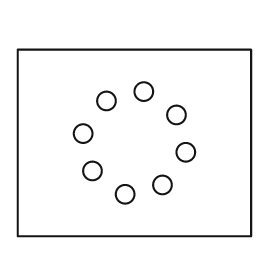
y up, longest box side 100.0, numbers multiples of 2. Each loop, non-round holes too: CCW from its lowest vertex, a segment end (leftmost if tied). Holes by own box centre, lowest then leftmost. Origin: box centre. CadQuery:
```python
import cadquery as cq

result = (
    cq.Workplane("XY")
    .moveTo(-50.0, -40.0)
    .lineTo(50.0, -40.0)
    .lineTo(50.0, 40.0)
    .lineTo(-50.0, 40.0)
    .close()
    .moveTo(-4.0, -22.0)
    .circle(4.0)
    .moveTo(12.0, -18.0)
    .circle(4.0)
    .moveTo(-18.0, -12.0)
    .circle(4.0)
    .moveTo(22.0, -4.0)
    .circle(4.0)
    .moveTo(-22.0, 4.0)
    .circle(4.0)
    .moveTo(18.0, 12.0)
    .circle(4.0)
    .moveTo(-12.0, 18.0)
    .circle(4.0)
    .moveTo(4.0, 22.0)
    .circle(4.0)
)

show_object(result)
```